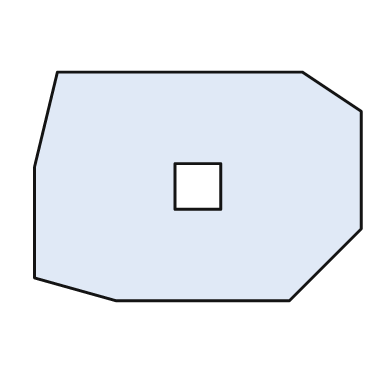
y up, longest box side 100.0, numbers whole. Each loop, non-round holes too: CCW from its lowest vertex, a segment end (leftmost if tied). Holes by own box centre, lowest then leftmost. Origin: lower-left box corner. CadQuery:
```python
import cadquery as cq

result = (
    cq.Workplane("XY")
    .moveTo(25.0, 0.0)
    .lineTo(78.0, 0.0)
    .lineTo(100.0, 22.0)
    .lineTo(100.0, 58.0)
    .lineTo(82.0, 70.0)
    .lineTo(7.0, 70.0)
    .lineTo(0.0, 41.0)
    .lineTo(0.0, 7.0)
    .close()
    .moveTo(43.0, 28.0)
    .lineTo(57.0, 28.0)
    .lineTo(57.0, 42.0)
    .lineTo(43.0, 42.0)
    .close()
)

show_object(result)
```